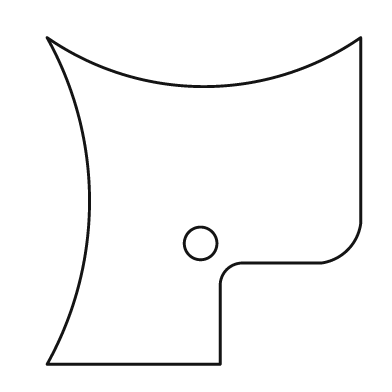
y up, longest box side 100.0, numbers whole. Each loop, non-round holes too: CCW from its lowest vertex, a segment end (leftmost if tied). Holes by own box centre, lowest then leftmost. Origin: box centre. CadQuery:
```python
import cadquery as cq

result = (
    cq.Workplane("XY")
    .moveTo(-48.0, -50.0)
    .lineTo(5.0, -50.0)
    .lineTo(5.0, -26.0)
    .threePointArc((7.0, -21.0), (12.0, -19.0))
    .lineTo(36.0, -19.0)
    .threePointArc((44.0, -15.0), (48.0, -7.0))
    .lineTo(48.0, 50.0)
    .threePointArc((0.0, 35.0), (-48.0, 50.0))
    .threePointArc((-35.0, 0.0), (-48.0, -50.0))
    .close()
    .moveTo(-1.0, -13.0)
    .circle(5.0)
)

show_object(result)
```